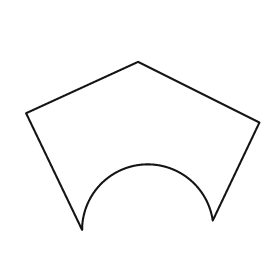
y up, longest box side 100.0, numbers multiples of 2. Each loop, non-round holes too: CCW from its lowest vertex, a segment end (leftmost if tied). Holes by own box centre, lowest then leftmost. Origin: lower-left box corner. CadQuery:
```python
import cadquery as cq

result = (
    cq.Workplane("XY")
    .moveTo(24.0, 0.0)
    .threePointArc((50.0, 28.0), (80.0, 4.0))
    .lineTo(100.0, 46.0)
    .lineTo(48.0, 72.0)
    .lineTo(0.0, 50.0)
    .close()
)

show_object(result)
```